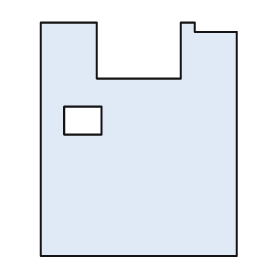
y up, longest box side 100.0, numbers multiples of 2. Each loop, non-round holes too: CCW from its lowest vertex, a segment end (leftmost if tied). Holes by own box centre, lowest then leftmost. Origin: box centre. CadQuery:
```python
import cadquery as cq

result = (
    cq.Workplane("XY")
    .moveTo(-42.0, -50.0)
    .lineTo(42.0, -50.0)
    .lineTo(42.0, 46.0)
    .lineTo(24.0, 46.0)
    .lineTo(24.0, 50.0)
    .lineTo(18.0, 50.0)
    .lineTo(18.0, 26.0)
    .lineTo(-18.0, 26.0)
    .lineTo(-18.0, 50.0)
    .lineTo(-42.0, 50.0)
    .close()
    .moveTo(-32.0, 2.0)
    .lineTo(-16.0, 2.0)
    .lineTo(-16.0, 14.0)
    .lineTo(-32.0, 14.0)
    .close()
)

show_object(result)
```